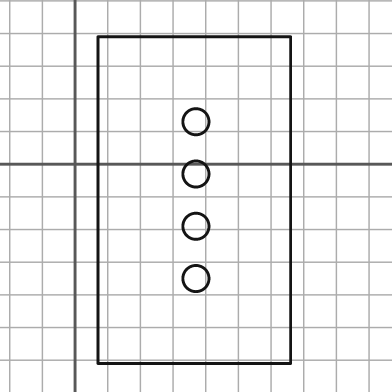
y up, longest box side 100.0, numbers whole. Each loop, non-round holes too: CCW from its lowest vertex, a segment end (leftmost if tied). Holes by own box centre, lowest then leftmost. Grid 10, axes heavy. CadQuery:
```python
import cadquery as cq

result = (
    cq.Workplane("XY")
    .moveTo(7.0, -61.0)
    .lineTo(66.0, -61.0)
    .lineTo(66.0, 39.0)
    .lineTo(7.0, 39.0)
    .close()
    .moveTo(37.0, -35.0)
    .circle(4.0)
    .moveTo(37.0, -19.0)
    .circle(4.0)
    .moveTo(37.0, -3.0)
    .circle(4.0)
    .moveTo(37.0, 13.0)
    .circle(4.0)
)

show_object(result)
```